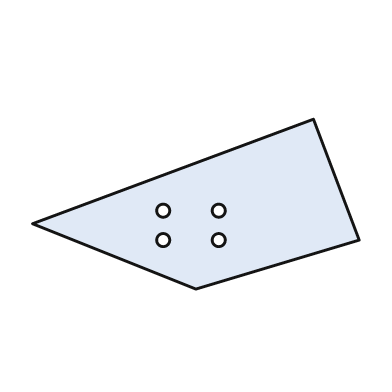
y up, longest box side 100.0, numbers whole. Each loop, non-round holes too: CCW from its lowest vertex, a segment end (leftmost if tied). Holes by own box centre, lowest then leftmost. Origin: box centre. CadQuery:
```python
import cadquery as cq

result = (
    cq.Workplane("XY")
    .moveTo(0.0, -26.0)
    .lineTo(50.0, -11.0)
    .lineTo(36.0, 26.0)
    .lineTo(-50.0, -6.0)
    .close()
    .moveTo(-10.0, -11.0)
    .circle(2.0)
    .moveTo(7.0, -11.0)
    .circle(2.0)
    .moveTo(-10.0, -2.0)
    .circle(2.0)
    .moveTo(7.0, -2.0)
    .circle(2.0)
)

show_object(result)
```